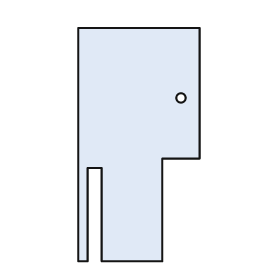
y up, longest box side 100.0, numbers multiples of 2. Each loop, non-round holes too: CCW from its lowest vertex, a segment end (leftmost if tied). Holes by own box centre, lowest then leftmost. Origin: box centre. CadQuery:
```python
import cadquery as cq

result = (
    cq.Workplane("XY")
    .moveTo(-26.0, -50.0)
    .lineTo(-22.0, -50.0)
    .lineTo(-22.0, -10.0)
    .lineTo(-16.0, -10.0)
    .lineTo(-16.0, -50.0)
    .lineTo(10.0, -50.0)
    .lineTo(10.0, -6.0)
    .lineTo(26.0, -6.0)
    .lineTo(26.0, 50.0)
    .lineTo(-26.0, 50.0)
    .close()
    .moveTo(18.0, 20.0)
    .circle(2.0)
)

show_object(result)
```